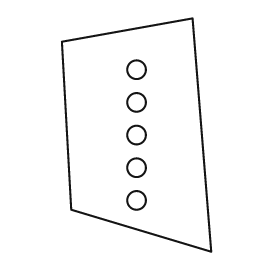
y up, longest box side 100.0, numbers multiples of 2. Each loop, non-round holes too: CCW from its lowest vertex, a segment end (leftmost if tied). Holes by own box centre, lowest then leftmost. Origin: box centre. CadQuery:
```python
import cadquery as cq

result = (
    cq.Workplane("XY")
    .moveTo(32.0, -50.0)
    .lineTo(24.0, 50.0)
    .lineTo(-32.0, 40.0)
    .lineTo(-28.0, -32.0)
    .close()
    .moveTo(0.0, -28.0)
    .circle(4.0)
    .moveTo(0.0, -14.0)
    .circle(4.0)
    .moveTo(0.0, 0.0)
    .circle(4.0)
    .moveTo(0.0, 14.0)
    .circle(4.0)
    .moveTo(0.0, 28.0)
    .circle(4.0)
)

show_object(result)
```